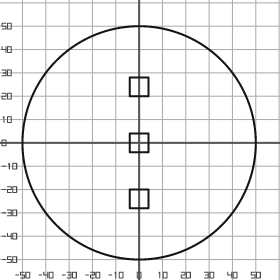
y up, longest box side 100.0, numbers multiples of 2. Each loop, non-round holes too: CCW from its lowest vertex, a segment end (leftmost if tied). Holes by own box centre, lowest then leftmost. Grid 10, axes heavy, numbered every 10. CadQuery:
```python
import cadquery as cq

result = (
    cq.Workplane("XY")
    .moveTo(0.0, 0.0)
    .circle(50.0)
    .moveTo(-4.0, -28.0)
    .lineTo(4.0, -28.0)
    .lineTo(4.0, -20.0)
    .lineTo(-4.0, -20.0)
    .close()
    .moveTo(-4.0, -4.0)
    .lineTo(4.0, -4.0)
    .lineTo(4.0, 4.0)
    .lineTo(-4.0, 4.0)
    .close()
    .moveTo(-4.0, 20.0)
    .lineTo(4.0, 20.0)
    .lineTo(4.0, 28.0)
    .lineTo(-4.0, 28.0)
    .close()
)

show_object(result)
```